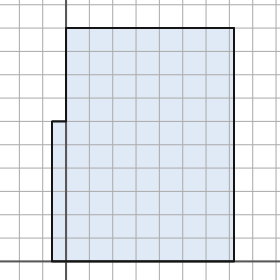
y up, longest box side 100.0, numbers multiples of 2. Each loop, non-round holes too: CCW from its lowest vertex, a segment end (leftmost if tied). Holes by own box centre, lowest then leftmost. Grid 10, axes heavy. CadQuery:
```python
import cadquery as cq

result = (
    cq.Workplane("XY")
    .moveTo(-6.0, 0.0)
    .lineTo(72.0, 0.0)
    .lineTo(72.0, 100.0)
    .lineTo(0.0, 100.0)
    .lineTo(0.0, 60.0)
    .lineTo(-6.0, 60.0)
    .close()
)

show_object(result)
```